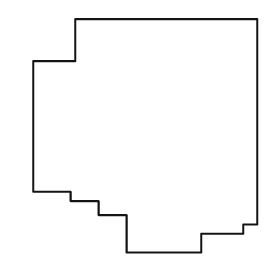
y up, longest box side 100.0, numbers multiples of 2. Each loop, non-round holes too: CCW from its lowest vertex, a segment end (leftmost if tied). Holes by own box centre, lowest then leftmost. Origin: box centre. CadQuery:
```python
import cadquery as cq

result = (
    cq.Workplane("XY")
    .moveTo(-8.0, -50.0)
    .lineTo(24.0, -50.0)
    .lineTo(24.0, -42.0)
    .lineTo(42.0, -42.0)
    .lineTo(42.0, -38.0)
    .lineTo(48.0, -38.0)
    .lineTo(48.0, 50.0)
    .lineTo(-30.0, 50.0)
    .lineTo(-30.0, 32.0)
    .lineTo(-48.0, 32.0)
    .lineTo(-48.0, -24.0)
    .lineTo(-32.0, -24.0)
    .lineTo(-32.0, -28.0)
    .lineTo(-20.0, -28.0)
    .lineTo(-20.0, -34.0)
    .lineTo(-8.0, -34.0)
    .close()
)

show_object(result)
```